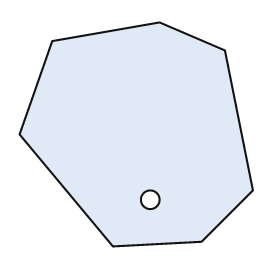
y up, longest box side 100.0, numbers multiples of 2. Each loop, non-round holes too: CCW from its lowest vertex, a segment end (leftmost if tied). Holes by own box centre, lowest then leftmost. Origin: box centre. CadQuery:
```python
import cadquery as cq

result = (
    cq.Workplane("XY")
    .moveTo(-10.0, -48.0)
    .lineTo(28.0, -46.0)
    .lineTo(50.0, -24.0)
    .lineTo(38.0, 36.0)
    .lineTo(10.0, 48.0)
    .lineTo(-36.0, 40.0)
    .lineTo(-50.0, 0.0)
    .close()
    .moveTo(6.0, -28.0)
    .circle(4.0)
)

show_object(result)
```